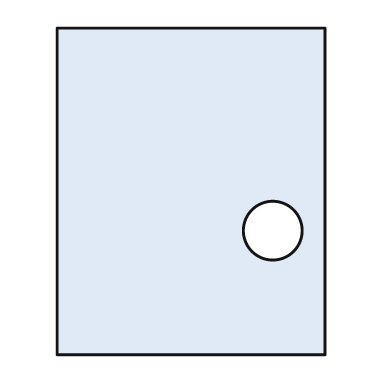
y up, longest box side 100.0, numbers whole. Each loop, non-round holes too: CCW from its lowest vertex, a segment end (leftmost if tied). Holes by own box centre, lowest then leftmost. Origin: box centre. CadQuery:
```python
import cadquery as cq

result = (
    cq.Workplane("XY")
    .moveTo(-41.0, -50.0)
    .lineTo(41.0, -50.0)
    .lineTo(41.0, 50.0)
    .lineTo(-41.0, 50.0)
    .close()
    .moveTo(25.0, -12.0)
    .circle(9.0)
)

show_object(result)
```